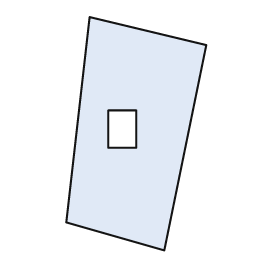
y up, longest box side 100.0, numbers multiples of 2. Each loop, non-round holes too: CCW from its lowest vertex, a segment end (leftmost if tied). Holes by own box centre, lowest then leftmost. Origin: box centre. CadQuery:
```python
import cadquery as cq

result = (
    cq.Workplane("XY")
    .moveTo(12.0, -50.0)
    .lineTo(30.0, 38.0)
    .lineTo(-20.0, 50.0)
    .lineTo(-30.0, -38.0)
    .close()
    .moveTo(-12.0, -6.0)
    .lineTo(0.0, -6.0)
    .lineTo(0.0, 10.0)
    .lineTo(-12.0, 10.0)
    .close()
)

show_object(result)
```